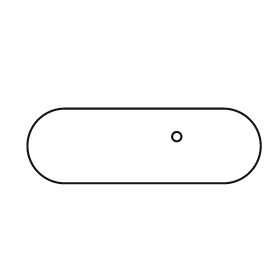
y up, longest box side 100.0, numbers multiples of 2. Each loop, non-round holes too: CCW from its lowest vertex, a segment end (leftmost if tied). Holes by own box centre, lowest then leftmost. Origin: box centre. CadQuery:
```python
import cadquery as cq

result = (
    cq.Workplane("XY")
    .moveTo(-34.0, -16.0)
    .lineTo(34.0, -16.0)
    .threePointArc((50.0, 0.0), (34.0, 16.0))
    .lineTo(-34.0, 16.0)
    .threePointArc((-50.0, 0.0), (-34.0, -16.0))
    .close()
    .moveTo(14.0, 4.0)
    .circle(2.0)
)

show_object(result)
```